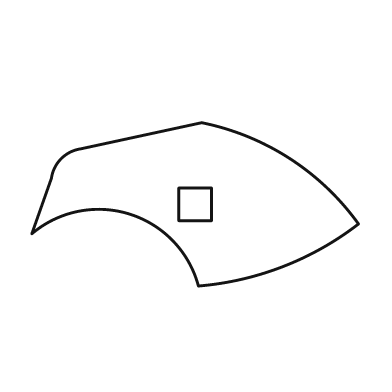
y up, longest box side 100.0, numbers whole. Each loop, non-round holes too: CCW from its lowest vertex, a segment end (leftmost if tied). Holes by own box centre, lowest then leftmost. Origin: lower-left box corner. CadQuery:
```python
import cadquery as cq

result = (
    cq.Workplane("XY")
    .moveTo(51.0, 0.0)
    .threePointArc((77.0, 6.0), (100.0, 19.0))
    .threePointArc((79.0, 39.0), (52.0, 50.0))
    .lineTo(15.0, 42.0)
    .threePointArc((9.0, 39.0), (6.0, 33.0))
    .lineTo(0.0, 16.0)
    .threePointArc((30.0, 22.0), (51.0, 0.0))
    .close()
    .moveTo(45.0, 20.0)
    .lineTo(55.0, 20.0)
    .lineTo(55.0, 30.0)
    .lineTo(45.0, 30.0)
    .close()
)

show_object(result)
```